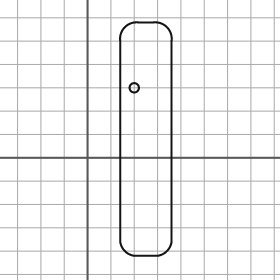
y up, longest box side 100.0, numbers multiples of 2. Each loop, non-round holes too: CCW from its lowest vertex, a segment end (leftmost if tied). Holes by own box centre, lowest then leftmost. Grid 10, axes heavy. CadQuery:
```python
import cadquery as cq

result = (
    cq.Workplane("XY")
    .moveTo(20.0, -42.0)
    .lineTo(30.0, -42.0)
    .threePointArc((34.0, -40.0), (36.0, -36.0))
    .lineTo(36.0, 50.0)
    .threePointArc((34.0, 56.0), (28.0, 58.0))
    .lineTo(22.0, 58.0)
    .threePointArc((16.0, 56.0), (14.0, 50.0))
    .lineTo(14.0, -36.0)
    .threePointArc((16.0, -40.0), (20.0, -42.0))
    .close()
    .moveTo(20.0, 30.0)
    .circle(2.0)
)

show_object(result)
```